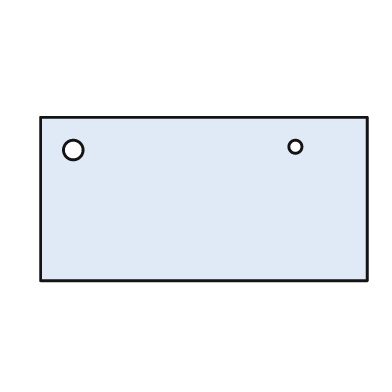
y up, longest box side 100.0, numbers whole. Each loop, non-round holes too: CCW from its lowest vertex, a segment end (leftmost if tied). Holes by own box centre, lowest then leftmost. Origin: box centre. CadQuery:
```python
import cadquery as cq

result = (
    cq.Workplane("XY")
    .moveTo(-50.0, -25.0)
    .lineTo(50.0, -25.0)
    .lineTo(50.0, 25.0)
    .lineTo(-50.0, 25.0)
    .close()
    .moveTo(-40.0, 15.0)
    .circle(3.0)
    .moveTo(28.0, 16.0)
    .circle(2.0)
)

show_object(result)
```